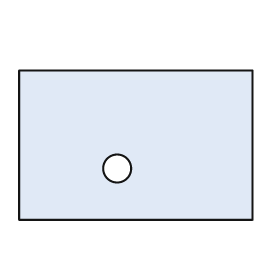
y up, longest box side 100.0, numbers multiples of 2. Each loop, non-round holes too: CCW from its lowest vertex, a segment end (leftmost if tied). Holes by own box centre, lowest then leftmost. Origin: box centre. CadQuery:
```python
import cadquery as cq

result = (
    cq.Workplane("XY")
    .moveTo(-50.0, -32.0)
    .lineTo(50.0, -32.0)
    .lineTo(50.0, 32.0)
    .lineTo(-50.0, 32.0)
    .close()
    .moveTo(-8.0, -10.0)
    .circle(6.0)
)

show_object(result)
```